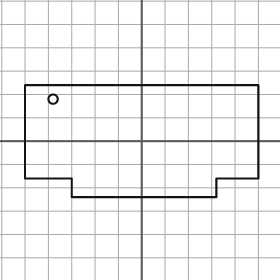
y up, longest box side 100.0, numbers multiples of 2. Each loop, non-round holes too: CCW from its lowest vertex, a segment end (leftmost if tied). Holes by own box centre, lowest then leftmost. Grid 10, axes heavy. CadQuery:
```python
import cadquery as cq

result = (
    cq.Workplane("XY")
    .moveTo(-30.0, -24.0)
    .lineTo(32.0, -24.0)
    .lineTo(32.0, -16.0)
    .lineTo(50.0, -16.0)
    .lineTo(50.0, 24.0)
    .lineTo(-50.0, 24.0)
    .lineTo(-50.0, -16.0)
    .lineTo(-30.0, -16.0)
    .close()
    .moveTo(-38.0, 18.0)
    .circle(2.0)
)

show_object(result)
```